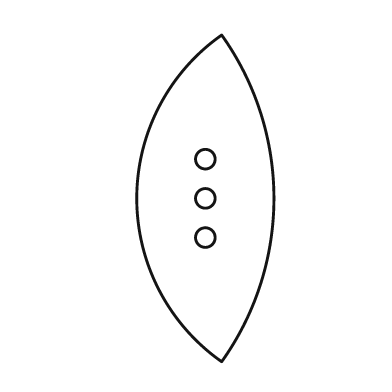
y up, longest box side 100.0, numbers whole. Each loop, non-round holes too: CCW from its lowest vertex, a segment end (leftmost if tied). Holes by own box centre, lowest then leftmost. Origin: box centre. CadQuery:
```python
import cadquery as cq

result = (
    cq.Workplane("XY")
    .moveTo(5.0, -50.0)
    .threePointArc((21.0, 0.0), (5.0, 50.0))
    .threePointArc((-21.0, 0.0), (5.0, -50.0))
    .close()
    .moveTo(0.0, -12.0)
    .circle(3.0)
    .moveTo(0.0, 0.0)
    .circle(3.0)
    .moveTo(0.0, 12.0)
    .circle(3.0)
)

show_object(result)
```